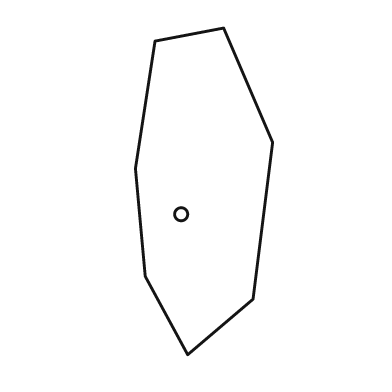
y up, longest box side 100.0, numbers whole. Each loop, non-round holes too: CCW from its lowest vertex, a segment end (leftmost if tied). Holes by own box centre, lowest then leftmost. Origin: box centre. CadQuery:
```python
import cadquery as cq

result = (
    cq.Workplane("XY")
    .moveTo(-5.0, -50.0)
    .lineTo(15.0, -33.0)
    .lineTo(21.0, 15.0)
    .lineTo(6.0, 50.0)
    .lineTo(-15.0, 46.0)
    .lineTo(-21.0, 7.0)
    .lineTo(-18.0, -26.0)
    .close()
    .moveTo(-7.0, -7.0)
    .circle(2.0)
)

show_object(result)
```